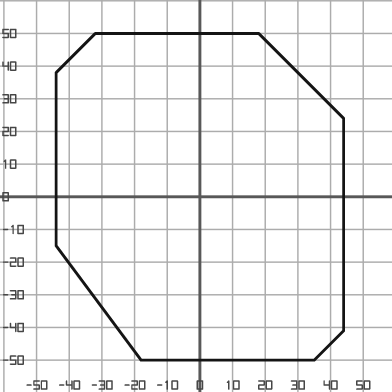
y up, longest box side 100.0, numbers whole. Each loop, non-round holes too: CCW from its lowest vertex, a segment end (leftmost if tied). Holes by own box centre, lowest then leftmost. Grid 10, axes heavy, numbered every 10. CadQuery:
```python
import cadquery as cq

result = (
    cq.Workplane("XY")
    .moveTo(-18.0, -50.0)
    .lineTo(35.0, -50.0)
    .lineTo(44.0, -41.0)
    .lineTo(44.0, 24.0)
    .lineTo(18.0, 50.0)
    .lineTo(-32.0, 50.0)
    .lineTo(-44.0, 38.0)
    .lineTo(-44.0, -15.0)
    .close()
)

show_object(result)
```